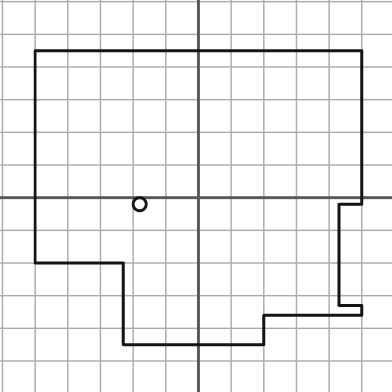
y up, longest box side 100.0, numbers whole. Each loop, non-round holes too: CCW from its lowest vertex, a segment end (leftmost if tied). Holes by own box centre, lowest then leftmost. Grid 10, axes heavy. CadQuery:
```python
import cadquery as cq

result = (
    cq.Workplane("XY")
    .moveTo(-23.0, -45.0)
    .lineTo(20.0, -45.0)
    .lineTo(20.0, -36.0)
    .lineTo(50.0, -36.0)
    .lineTo(50.0, -33.0)
    .lineTo(43.0, -33.0)
    .lineTo(43.0, -2.0)
    .lineTo(50.0, -2.0)
    .lineTo(50.0, 45.0)
    .lineTo(-50.0, 45.0)
    .lineTo(-50.0, -20.0)
    .lineTo(-23.0, -20.0)
    .close()
    .moveTo(-18.0, -2.0)
    .circle(2.0)
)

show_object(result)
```